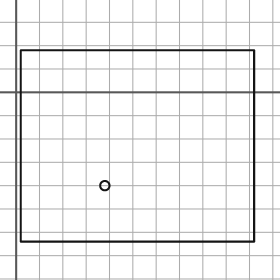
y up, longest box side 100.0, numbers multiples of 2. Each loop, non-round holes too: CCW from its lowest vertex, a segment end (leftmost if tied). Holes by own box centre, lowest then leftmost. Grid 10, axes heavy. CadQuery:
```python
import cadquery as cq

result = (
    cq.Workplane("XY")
    .moveTo(2.0, -64.0)
    .lineTo(102.0, -64.0)
    .lineTo(102.0, 18.0)
    .lineTo(2.0, 18.0)
    .close()
    .moveTo(38.0, -40.0)
    .circle(2.0)
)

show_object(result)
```